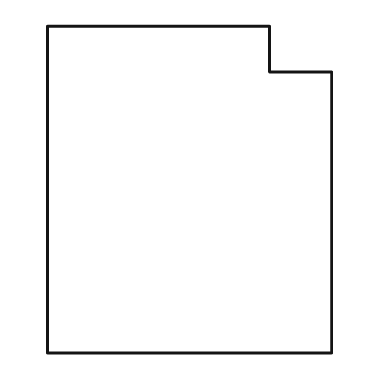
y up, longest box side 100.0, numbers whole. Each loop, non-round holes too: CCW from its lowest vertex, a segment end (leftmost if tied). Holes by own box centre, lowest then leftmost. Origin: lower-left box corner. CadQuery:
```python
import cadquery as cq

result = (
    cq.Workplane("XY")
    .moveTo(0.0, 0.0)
    .lineTo(87.0, 0.0)
    .lineTo(87.0, 86.0)
    .lineTo(68.0, 86.0)
    .lineTo(68.0, 100.0)
    .lineTo(0.0, 100.0)
    .close()
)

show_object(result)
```